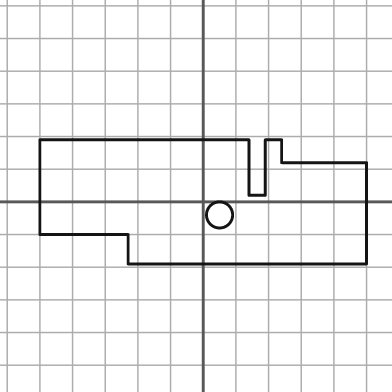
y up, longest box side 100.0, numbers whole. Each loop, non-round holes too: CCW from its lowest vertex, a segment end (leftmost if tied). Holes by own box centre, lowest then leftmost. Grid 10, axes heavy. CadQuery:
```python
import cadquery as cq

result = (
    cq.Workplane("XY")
    .moveTo(-23.0, -19.0)
    .lineTo(50.0, -19.0)
    .lineTo(50.0, 12.0)
    .lineTo(24.0, 12.0)
    .lineTo(24.0, 19.0)
    .lineTo(19.0, 19.0)
    .lineTo(19.0, 2.0)
    .lineTo(14.0, 2.0)
    .lineTo(14.0, 19.0)
    .lineTo(-50.0, 19.0)
    .lineTo(-50.0, -10.0)
    .lineTo(-23.0, -10.0)
    .close()
    .moveTo(5.0, -4.0)
    .circle(4.0)
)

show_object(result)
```